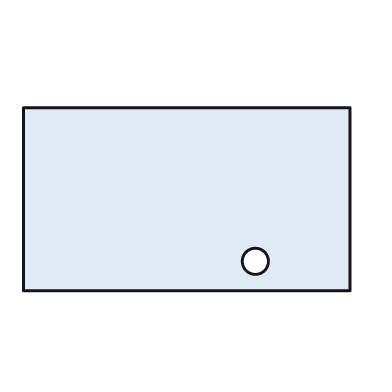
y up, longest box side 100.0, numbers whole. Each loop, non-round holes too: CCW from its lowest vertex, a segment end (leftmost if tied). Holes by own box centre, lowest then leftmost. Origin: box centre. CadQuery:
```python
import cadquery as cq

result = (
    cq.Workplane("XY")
    .moveTo(-50.0, -28.0)
    .lineTo(50.0, -28.0)
    .lineTo(50.0, 28.0)
    .lineTo(-50.0, 28.0)
    .close()
    .moveTo(21.0, -19.0)
    .circle(4.0)
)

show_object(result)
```